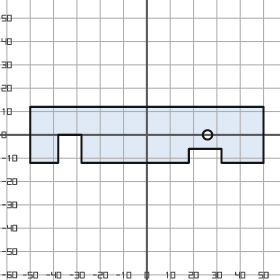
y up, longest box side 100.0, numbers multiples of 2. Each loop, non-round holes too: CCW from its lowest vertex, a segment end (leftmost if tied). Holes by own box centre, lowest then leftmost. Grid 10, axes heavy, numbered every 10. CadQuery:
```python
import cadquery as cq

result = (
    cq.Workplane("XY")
    .moveTo(-50.0, -12.0)
    .lineTo(-38.0, -12.0)
    .lineTo(-38.0, 0.0)
    .lineTo(-28.0, 0.0)
    .lineTo(-28.0, -12.0)
    .lineTo(18.0, -12.0)
    .lineTo(18.0, -6.0)
    .lineTo(32.0, -6.0)
    .lineTo(32.0, -12.0)
    .lineTo(50.0, -12.0)
    .lineTo(50.0, 12.0)
    .lineTo(-50.0, 12.0)
    .close()
    .moveTo(26.0, 0.0)
    .circle(2.0)
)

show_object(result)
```